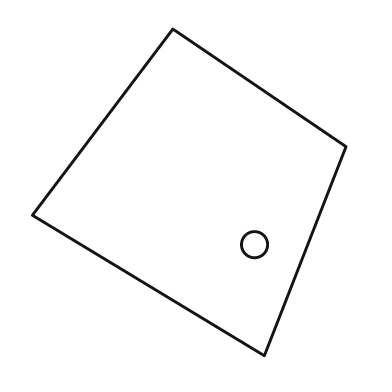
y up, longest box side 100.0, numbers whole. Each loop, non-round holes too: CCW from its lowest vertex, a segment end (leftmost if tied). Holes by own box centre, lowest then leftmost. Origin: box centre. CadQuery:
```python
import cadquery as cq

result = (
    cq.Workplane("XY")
    .moveTo(23.0, -50.0)
    .lineTo(48.0, 14.0)
    .lineTo(-5.0, 50.0)
    .lineTo(-48.0, -7.0)
    .close()
    .moveTo(20.0, -16.0)
    .circle(4.0)
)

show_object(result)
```